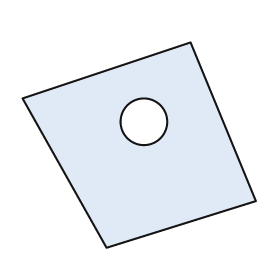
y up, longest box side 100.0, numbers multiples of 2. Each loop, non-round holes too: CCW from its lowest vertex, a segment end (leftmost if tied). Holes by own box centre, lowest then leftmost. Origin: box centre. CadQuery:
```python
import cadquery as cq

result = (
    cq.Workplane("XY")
    .moveTo(-14.0, -44.0)
    .lineTo(50.0, -24.0)
    .lineTo(22.0, 44.0)
    .lineTo(-50.0, 20.0)
    .close()
    .moveTo(2.0, 10.0)
    .circle(10.0)
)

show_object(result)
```